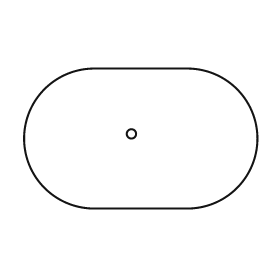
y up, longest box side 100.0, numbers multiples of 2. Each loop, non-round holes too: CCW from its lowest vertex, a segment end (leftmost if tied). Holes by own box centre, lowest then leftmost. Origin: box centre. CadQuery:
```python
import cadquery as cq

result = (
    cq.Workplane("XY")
    .moveTo(-20.0, -30.0)
    .lineTo(20.0, -30.0)
    .threePointArc((50.0, 0.0), (20.0, 30.0))
    .lineTo(-20.0, 30.0)
    .threePointArc((-50.0, 0.0), (-20.0, -30.0))
    .close()
    .moveTo(-4.0, 2.0)
    .circle(2.0)
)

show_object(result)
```